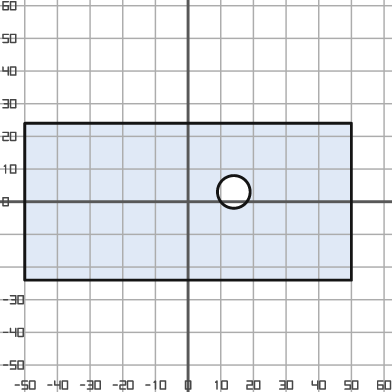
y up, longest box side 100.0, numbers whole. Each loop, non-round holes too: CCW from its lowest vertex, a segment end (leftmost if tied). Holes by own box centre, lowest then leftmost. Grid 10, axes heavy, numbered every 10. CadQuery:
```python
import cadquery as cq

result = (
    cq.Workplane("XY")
    .moveTo(-50.0, -24.0)
    .lineTo(50.0, -24.0)
    .lineTo(50.0, 24.0)
    .lineTo(-50.0, 24.0)
    .close()
    .moveTo(14.0, 3.0)
    .circle(5.0)
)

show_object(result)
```